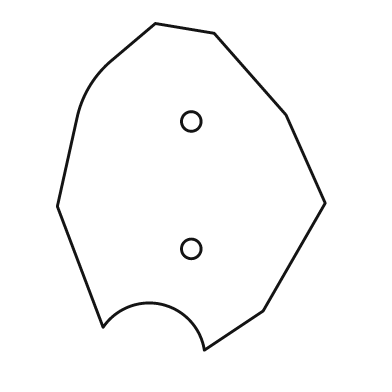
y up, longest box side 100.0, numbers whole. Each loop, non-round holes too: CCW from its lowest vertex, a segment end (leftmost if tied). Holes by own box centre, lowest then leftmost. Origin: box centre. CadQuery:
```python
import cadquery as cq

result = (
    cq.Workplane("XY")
    .moveTo(4.0, -50.0)
    .lineTo(22.0, -38.0)
    .lineTo(41.0, -5.0)
    .lineTo(29.0, 22.0)
    .lineTo(7.0, 47.0)
    .lineTo(-11.0, 50.0)
    .lineTo(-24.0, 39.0)
    .threePointArc((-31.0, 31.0), (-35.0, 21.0))
    .lineTo(-41.0, -6.0)
    .lineTo(-27.0, -43.0)
    .threePointArc((-9.0, -36.0), (4.0, -50.0))
    .close()
    .moveTo(0.0, -19.0)
    .circle(3.0)
    .moveTo(0.0, 20.0)
    .circle(3.0)
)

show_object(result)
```